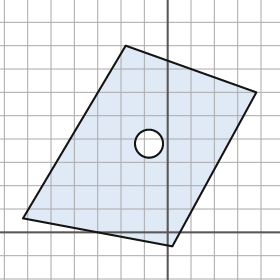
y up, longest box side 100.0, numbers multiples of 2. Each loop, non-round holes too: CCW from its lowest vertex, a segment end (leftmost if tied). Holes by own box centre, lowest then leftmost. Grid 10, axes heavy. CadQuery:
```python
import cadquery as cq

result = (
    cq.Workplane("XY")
    .moveTo(2.0, -6.0)
    .lineTo(38.0, 60.0)
    .lineTo(-18.0, 80.0)
    .lineTo(-62.0, 6.0)
    .close()
    .moveTo(-8.0, 38.0)
    .circle(6.0)
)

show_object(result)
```